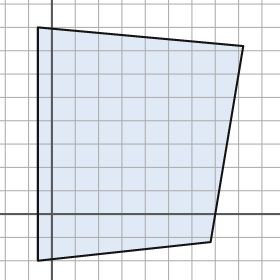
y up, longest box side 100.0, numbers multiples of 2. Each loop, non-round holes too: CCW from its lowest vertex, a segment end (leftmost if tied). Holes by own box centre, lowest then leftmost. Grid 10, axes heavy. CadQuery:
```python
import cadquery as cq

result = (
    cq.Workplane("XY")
    .moveTo(-6.0, -20.0)
    .lineTo(68.0, -12.0)
    .lineTo(82.0, 72.0)
    .lineTo(-6.0, 80.0)
    .close()
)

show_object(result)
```